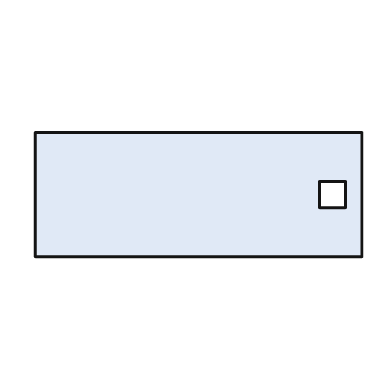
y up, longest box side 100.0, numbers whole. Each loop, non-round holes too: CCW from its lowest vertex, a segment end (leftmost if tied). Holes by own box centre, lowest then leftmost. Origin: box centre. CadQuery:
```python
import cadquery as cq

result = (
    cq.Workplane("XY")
    .moveTo(-50.0, -19.0)
    .lineTo(50.0, -19.0)
    .lineTo(50.0, 19.0)
    .lineTo(-50.0, 19.0)
    .close()
    .moveTo(37.0, -4.0)
    .lineTo(45.0, -4.0)
    .lineTo(45.0, 4.0)
    .lineTo(37.0, 4.0)
    .close()
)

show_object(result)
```